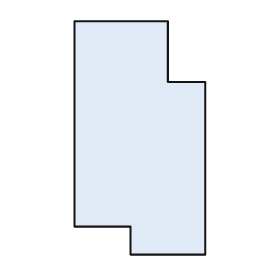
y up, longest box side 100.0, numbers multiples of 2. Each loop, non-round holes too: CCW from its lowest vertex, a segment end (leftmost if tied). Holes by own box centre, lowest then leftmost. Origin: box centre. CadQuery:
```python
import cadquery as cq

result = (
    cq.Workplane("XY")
    .moveTo(-4.0, -50.0)
    .lineTo(28.0, -50.0)
    .lineTo(28.0, 24.0)
    .lineTo(12.0, 24.0)
    .lineTo(12.0, 50.0)
    .lineTo(-28.0, 50.0)
    .lineTo(-28.0, -38.0)
    .lineTo(-4.0, -38.0)
    .close()
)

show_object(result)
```